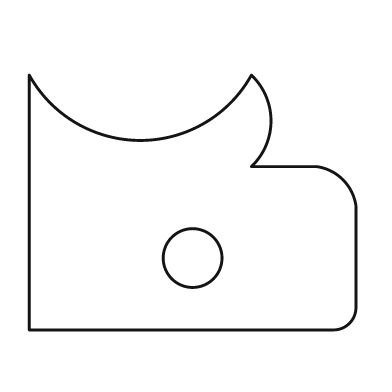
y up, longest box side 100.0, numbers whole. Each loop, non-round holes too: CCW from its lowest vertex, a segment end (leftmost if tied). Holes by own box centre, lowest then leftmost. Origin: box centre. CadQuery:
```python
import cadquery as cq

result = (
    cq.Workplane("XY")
    .moveTo(-50.0, -39.0)
    .lineTo(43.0, -39.0)
    .threePointArc((48.0, -37.0), (50.0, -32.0))
    .lineTo(50.0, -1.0)
    .threePointArc((46.0, 7.0), (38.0, 11.0))
    .lineTo(18.0, 11.0)
    .threePointArc((24.0, 25.0), (18.0, 39.0))
    .threePointArc((-16.0, 19.0), (-50.0, 39.0))
    .close()
    .moveTo(0.0, -17.0)
    .circle(9.0)
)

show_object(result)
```